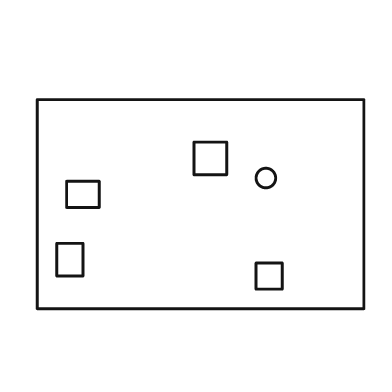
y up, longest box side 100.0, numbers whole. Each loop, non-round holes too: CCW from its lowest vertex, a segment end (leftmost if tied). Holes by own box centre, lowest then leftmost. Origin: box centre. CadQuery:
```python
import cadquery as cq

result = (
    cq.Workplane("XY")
    .moveTo(-50.0, -32.0)
    .lineTo(50.0, -32.0)
    .lineTo(50.0, 32.0)
    .lineTo(-50.0, 32.0)
    .close()
    .moveTo(17.0, -26.0)
    .lineTo(25.0, -26.0)
    .lineTo(25.0, -18.0)
    .lineTo(17.0, -18.0)
    .close()
    .moveTo(-44.0, -22.0)
    .lineTo(-36.0, -22.0)
    .lineTo(-36.0, -12.0)
    .lineTo(-44.0, -12.0)
    .close()
    .moveTo(-41.0, -1.0)
    .lineTo(-31.0, -1.0)
    .lineTo(-31.0, 7.0)
    .lineTo(-41.0, 7.0)
    .close()
    .moveTo(20.0, 8.0)
    .circle(3.0)
    .moveTo(-2.0, 9.0)
    .lineTo(8.0, 9.0)
    .lineTo(8.0, 19.0)
    .lineTo(-2.0, 19.0)
    .close()
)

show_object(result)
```